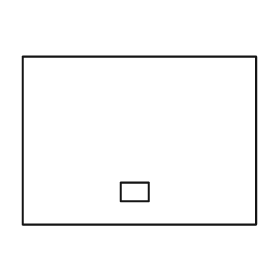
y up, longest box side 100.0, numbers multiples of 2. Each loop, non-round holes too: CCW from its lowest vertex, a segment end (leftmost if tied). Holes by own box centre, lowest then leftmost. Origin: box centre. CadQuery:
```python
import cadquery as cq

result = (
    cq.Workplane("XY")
    .moveTo(-50.0, -36.0)
    .lineTo(50.0, -36.0)
    .lineTo(50.0, 36.0)
    .lineTo(-50.0, 36.0)
    .close()
    .moveTo(-8.0, -26.0)
    .lineTo(4.0, -26.0)
    .lineTo(4.0, -18.0)
    .lineTo(-8.0, -18.0)
    .close()
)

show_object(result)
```